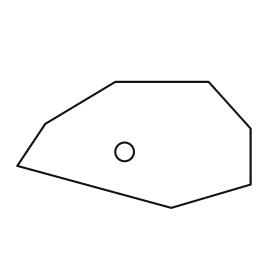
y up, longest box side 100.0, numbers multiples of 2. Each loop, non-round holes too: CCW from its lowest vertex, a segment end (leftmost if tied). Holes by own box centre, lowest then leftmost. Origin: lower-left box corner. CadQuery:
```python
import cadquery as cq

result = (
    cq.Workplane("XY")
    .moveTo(66.0, 0.0)
    .lineTo(100.0, 10.0)
    .lineTo(100.0, 34.0)
    .lineTo(82.0, 54.0)
    .lineTo(42.0, 54.0)
    .lineTo(12.0, 36.0)
    .lineTo(0.0, 18.0)
    .close()
    .moveTo(46.0, 24.0)
    .circle(4.0)
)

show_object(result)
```